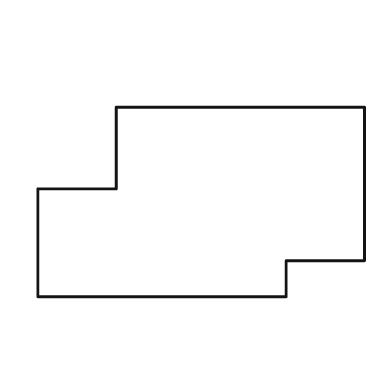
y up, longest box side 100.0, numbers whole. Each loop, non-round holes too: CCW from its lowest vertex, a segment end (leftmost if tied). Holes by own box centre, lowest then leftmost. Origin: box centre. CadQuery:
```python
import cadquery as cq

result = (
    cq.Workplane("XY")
    .moveTo(-50.0, -29.0)
    .lineTo(26.0, -29.0)
    .lineTo(26.0, -18.0)
    .lineTo(50.0, -18.0)
    .lineTo(50.0, 29.0)
    .lineTo(-26.0, 29.0)
    .lineTo(-26.0, 4.0)
    .lineTo(-50.0, 4.0)
    .close()
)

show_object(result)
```